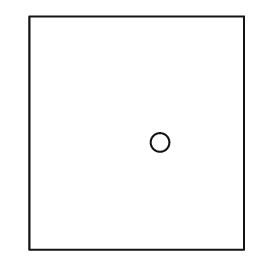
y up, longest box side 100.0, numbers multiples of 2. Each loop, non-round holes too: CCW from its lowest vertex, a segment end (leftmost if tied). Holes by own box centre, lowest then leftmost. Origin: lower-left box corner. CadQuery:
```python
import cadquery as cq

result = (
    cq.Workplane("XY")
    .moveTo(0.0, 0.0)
    .lineTo(92.0, 0.0)
    .lineTo(92.0, 100.0)
    .lineTo(0.0, 100.0)
    .close()
    .moveTo(56.0, 46.0)
    .circle(4.0)
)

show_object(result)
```